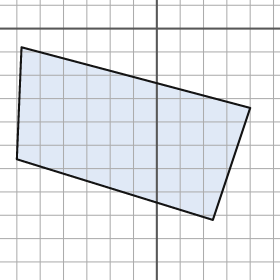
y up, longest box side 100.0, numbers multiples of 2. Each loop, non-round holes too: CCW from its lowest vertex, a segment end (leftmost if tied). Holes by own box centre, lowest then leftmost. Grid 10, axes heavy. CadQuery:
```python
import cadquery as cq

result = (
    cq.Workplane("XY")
    .moveTo(24.0, -82.0)
    .lineTo(40.0, -34.0)
    .lineTo(-58.0, -8.0)
    .lineTo(-60.0, -56.0)
    .close()
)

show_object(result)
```